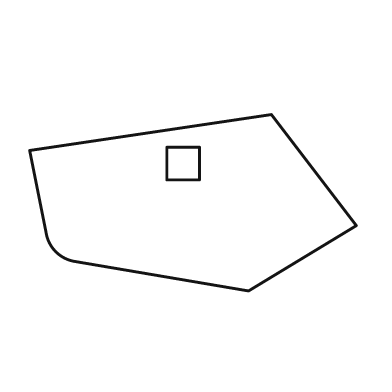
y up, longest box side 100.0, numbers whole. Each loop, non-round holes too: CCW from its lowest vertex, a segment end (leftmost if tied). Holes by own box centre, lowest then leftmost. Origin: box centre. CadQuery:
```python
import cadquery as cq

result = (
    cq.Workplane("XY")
    .moveTo(17.0, -27.0)
    .lineTo(50.0, -7.0)
    .lineTo(24.0, 27.0)
    .lineTo(-50.0, 16.0)
    .lineTo(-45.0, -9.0)
    .threePointArc((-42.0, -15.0), (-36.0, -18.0))
    .close()
    .moveTo(-8.0, 7.0)
    .lineTo(2.0, 7.0)
    .lineTo(2.0, 17.0)
    .lineTo(-8.0, 17.0)
    .close()
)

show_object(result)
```